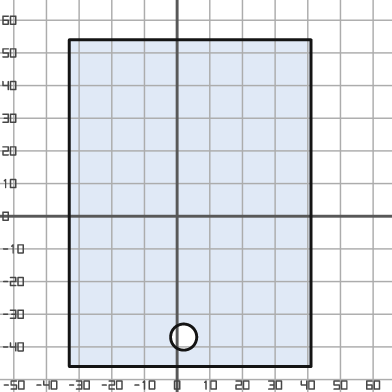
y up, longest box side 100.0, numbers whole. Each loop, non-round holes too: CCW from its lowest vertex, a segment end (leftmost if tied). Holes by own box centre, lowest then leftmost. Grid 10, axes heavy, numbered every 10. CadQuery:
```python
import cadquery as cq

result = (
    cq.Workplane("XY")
    .moveTo(-33.0, -46.0)
    .lineTo(41.0, -46.0)
    .lineTo(41.0, 54.0)
    .lineTo(-33.0, 54.0)
    .close()
    .moveTo(2.0, -37.0)
    .circle(4.0)
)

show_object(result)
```